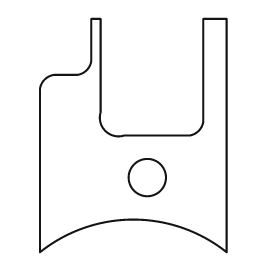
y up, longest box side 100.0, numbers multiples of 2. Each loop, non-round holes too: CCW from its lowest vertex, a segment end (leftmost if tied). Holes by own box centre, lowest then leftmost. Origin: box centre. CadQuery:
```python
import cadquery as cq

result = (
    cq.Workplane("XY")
    .moveTo(-40.0, -50.0)
    .threePointArc((0.0, -36.0), (40.0, -50.0))
    .lineTo(40.0, 50.0)
    .lineTo(30.0, 50.0)
    .lineTo(30.0, 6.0)
    .threePointArc((28.0, 2.0), (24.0, 0.0))
    .lineTo(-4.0, 0.0)
    .threePointArc((-12.0, 2.0), (-14.0, 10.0))
    .lineTo(-14.0, 50.0)
    .lineTo(-18.0, 50.0)
    .lineTo(-18.0, 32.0)
    .threePointArc((-20.0, 28.0), (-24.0, 26.0))
    .lineTo(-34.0, 26.0)
    .threePointArc((-38.0, 24.0), (-40.0, 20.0))
    .close()
    .moveTo(6.0, -18.0)
    .circle(8.0)
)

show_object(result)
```